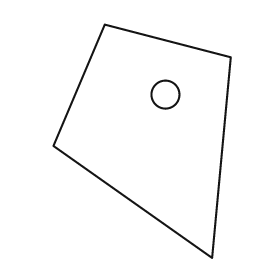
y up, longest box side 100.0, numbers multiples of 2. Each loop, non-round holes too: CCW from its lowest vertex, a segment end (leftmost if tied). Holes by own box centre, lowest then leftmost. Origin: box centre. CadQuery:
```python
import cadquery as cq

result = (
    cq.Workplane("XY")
    .moveTo(30.0, -50.0)
    .lineTo(38.0, 36.0)
    .lineTo(-16.0, 50.0)
    .lineTo(-38.0, -2.0)
    .close()
    .moveTo(10.0, 20.0)
    .circle(6.0)
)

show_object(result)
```